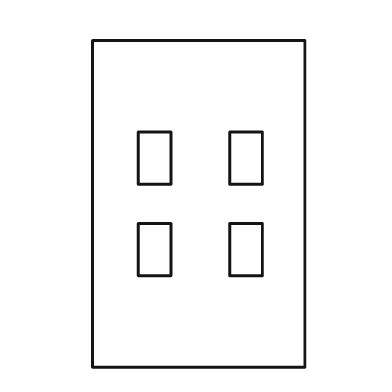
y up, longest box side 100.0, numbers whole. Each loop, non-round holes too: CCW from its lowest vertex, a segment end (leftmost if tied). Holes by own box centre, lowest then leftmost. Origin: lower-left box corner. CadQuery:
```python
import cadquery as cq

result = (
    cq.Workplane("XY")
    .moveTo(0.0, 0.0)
    .lineTo(65.0, 0.0)
    .lineTo(65.0, 100.0)
    .lineTo(0.0, 100.0)
    .close()
    .moveTo(14.0, 28.0)
    .lineTo(24.0, 28.0)
    .lineTo(24.0, 44.0)
    .lineTo(14.0, 44.0)
    .close()
    .moveTo(42.0, 28.0)
    .lineTo(52.0, 28.0)
    .lineTo(52.0, 44.0)
    .lineTo(42.0, 44.0)
    .close()
    .moveTo(14.0, 56.0)
    .lineTo(24.0, 56.0)
    .lineTo(24.0, 72.0)
    .lineTo(14.0, 72.0)
    .close()
    .moveTo(42.0, 56.0)
    .lineTo(52.0, 56.0)
    .lineTo(52.0, 72.0)
    .lineTo(42.0, 72.0)
    .close()
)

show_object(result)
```